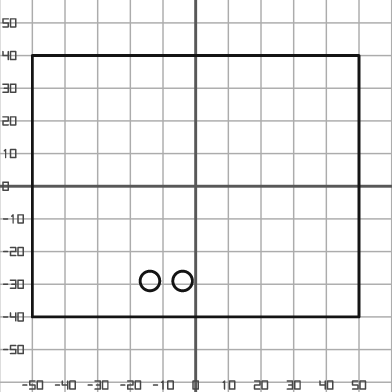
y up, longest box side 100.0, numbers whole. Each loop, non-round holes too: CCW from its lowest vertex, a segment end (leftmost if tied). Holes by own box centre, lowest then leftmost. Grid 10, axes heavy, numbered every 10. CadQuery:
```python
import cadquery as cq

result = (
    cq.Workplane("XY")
    .moveTo(-50.0, -40.0)
    .lineTo(50.0, -40.0)
    .lineTo(50.0, 40.0)
    .lineTo(-50.0, 40.0)
    .close()
    .moveTo(-14.0, -29.0)
    .circle(3.0)
    .moveTo(-4.0, -29.0)
    .circle(3.0)
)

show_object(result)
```